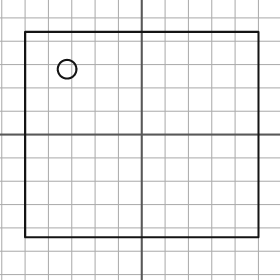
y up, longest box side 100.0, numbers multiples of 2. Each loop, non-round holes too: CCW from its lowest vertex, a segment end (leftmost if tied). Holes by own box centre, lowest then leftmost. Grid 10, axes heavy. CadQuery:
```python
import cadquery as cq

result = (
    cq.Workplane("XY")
    .moveTo(-50.0, -44.0)
    .lineTo(50.0, -44.0)
    .lineTo(50.0, 44.0)
    .lineTo(-50.0, 44.0)
    .close()
    .moveTo(-32.0, 28.0)
    .circle(4.0)
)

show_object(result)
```